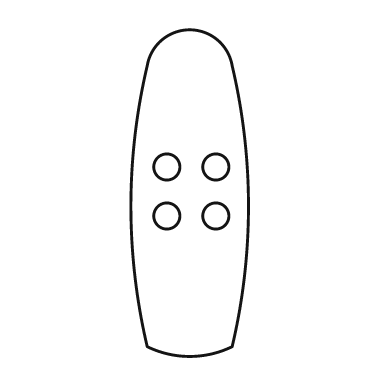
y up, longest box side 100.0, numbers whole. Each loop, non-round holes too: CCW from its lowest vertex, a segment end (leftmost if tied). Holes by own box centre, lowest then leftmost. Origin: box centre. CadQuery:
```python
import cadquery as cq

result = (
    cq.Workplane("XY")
    .moveTo(-13.0, -47.0)
    .threePointArc((0.0, -50.0), (13.0, -47.0))
    .threePointArc((18.0, -4.0), (13.0, 39.0))
    .threePointArc((0.0, 50.0), (-13.0, 39.0))
    .threePointArc((-18.0, -4.0), (-13.0, -47.0))
    .close()
    .moveTo(-7.0, -7.0)
    .circle(4.0)
    .moveTo(8.0, -7.0)
    .circle(4.0)
    .moveTo(-7.0, 8.0)
    .circle(4.0)
    .moveTo(8.0, 8.0)
    .circle(4.0)
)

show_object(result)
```